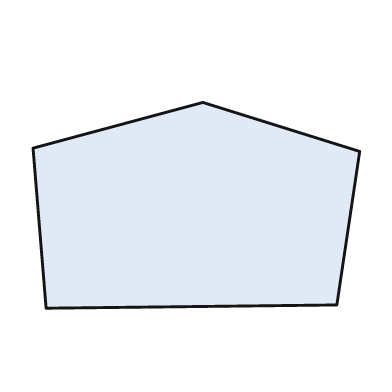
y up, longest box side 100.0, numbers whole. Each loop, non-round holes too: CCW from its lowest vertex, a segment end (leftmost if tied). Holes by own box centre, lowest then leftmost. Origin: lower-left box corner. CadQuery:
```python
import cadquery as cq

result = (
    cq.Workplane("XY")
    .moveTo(4.0, 0.0)
    .lineTo(93.0, 1.0)
    .lineTo(100.0, 48.0)
    .lineTo(52.0, 63.0)
    .lineTo(0.0, 49.0)
    .close()
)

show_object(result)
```